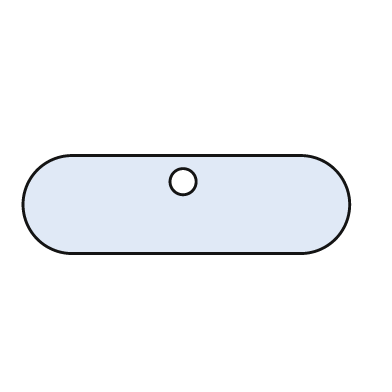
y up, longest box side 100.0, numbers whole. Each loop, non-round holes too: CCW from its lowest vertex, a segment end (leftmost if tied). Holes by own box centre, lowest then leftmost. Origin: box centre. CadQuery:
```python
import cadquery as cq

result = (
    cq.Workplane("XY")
    .moveTo(-35.0, -15.0)
    .lineTo(35.0, -15.0)
    .threePointArc((50.0, 0.0), (35.0, 15.0))
    .lineTo(-35.0, 15.0)
    .threePointArc((-50.0, 0.0), (-35.0, -15.0))
    .close()
    .moveTo(-1.0, 7.0)
    .circle(4.0)
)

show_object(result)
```